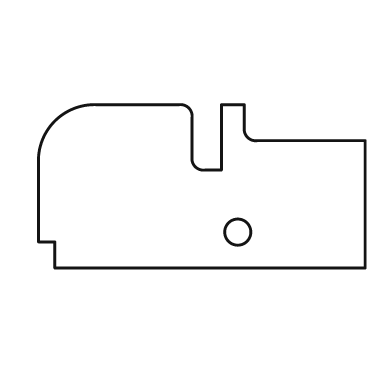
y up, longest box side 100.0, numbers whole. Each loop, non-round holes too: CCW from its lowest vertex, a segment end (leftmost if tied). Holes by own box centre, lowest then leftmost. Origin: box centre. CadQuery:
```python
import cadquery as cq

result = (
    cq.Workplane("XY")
    .moveTo(-45.0, -25.0)
    .lineTo(50.0, -25.0)
    .lineTo(50.0, 14.0)
    .lineTo(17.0, 14.0)
    .threePointArc((14.0, 15.0), (13.0, 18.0))
    .lineTo(13.0, 25.0)
    .lineTo(6.0, 25.0)
    .lineTo(6.0, 5.0)
    .lineTo(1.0, 5.0)
    .threePointArc((-2.0, 6.0), (-3.0, 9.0))
    .lineTo(-3.0, 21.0)
    .threePointArc((-4.0, 24.0), (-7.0, 25.0))
    .lineTo(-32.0, 25.0)
    .threePointArc((-45.0, 20.0), (-50.0, 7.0))
    .lineTo(-50.0, -17.0)
    .lineTo(-45.0, -17.0)
    .close()
    .moveTo(11.0, -14.0)
    .circle(4.0)
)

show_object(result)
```